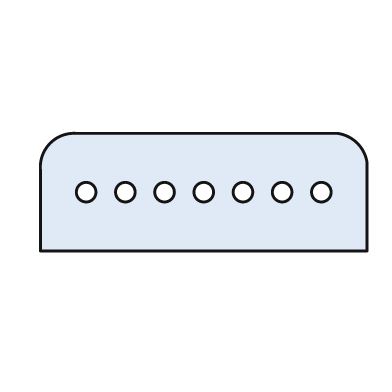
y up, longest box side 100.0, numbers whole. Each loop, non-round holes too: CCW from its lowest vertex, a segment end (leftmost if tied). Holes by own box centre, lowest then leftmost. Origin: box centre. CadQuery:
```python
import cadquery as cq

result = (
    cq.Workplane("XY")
    .moveTo(-50.0, -18.0)
    .lineTo(50.0, -18.0)
    .lineTo(50.0, 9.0)
    .threePointArc((47.0, 15.0), (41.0, 18.0))
    .lineTo(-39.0, 18.0)
    .threePointArc((-47.0, 15.0), (-50.0, 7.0))
    .close()
    .moveTo(-36.0, 0.0)
    .circle(3.0)
    .moveTo(-24.0, 0.0)
    .circle(3.0)
    .moveTo(-12.0, 0.0)
    .circle(3.0)
    .moveTo(0.0, 0.0)
    .circle(3.0)
    .moveTo(12.0, 0.0)
    .circle(3.0)
    .moveTo(24.0, 0.0)
    .circle(3.0)
    .moveTo(36.0, 0.0)
    .circle(3.0)
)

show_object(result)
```